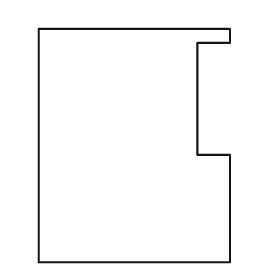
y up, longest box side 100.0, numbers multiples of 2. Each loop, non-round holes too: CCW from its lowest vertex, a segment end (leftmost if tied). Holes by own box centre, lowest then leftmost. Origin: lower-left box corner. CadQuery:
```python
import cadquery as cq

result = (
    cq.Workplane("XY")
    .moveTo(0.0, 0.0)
    .lineTo(82.0, 0.0)
    .lineTo(82.0, 46.0)
    .lineTo(68.0, 46.0)
    .lineTo(68.0, 94.0)
    .lineTo(82.0, 94.0)
    .lineTo(82.0, 100.0)
    .lineTo(0.0, 100.0)
    .close()
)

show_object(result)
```